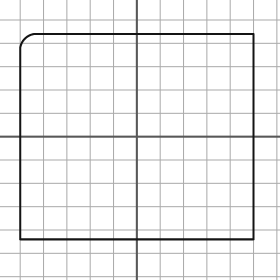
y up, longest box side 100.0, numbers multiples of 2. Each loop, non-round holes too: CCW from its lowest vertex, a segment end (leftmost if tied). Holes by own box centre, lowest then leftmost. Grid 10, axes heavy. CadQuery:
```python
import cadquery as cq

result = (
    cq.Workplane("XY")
    .moveTo(-50.0, -44.0)
    .lineTo(50.0, -44.0)
    .lineTo(50.0, 44.0)
    .lineTo(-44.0, 44.0)
    .threePointArc((-48.0, 42.0), (-50.0, 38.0))
    .close()
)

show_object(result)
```